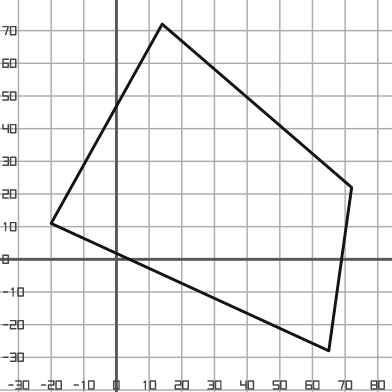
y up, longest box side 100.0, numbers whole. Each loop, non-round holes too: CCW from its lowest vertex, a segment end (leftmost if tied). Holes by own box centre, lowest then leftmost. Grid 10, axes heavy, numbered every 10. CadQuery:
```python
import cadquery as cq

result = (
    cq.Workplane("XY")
    .moveTo(65.0, -28.0)
    .lineTo(72.0, 22.0)
    .lineTo(14.0, 72.0)
    .lineTo(-20.0, 11.0)
    .close()
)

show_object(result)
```